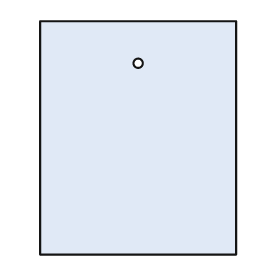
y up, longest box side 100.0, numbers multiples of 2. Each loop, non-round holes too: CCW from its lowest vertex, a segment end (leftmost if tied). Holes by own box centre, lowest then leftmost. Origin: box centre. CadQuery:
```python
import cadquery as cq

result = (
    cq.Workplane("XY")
    .moveTo(-42.0, -50.0)
    .lineTo(42.0, -50.0)
    .lineTo(42.0, 50.0)
    .lineTo(-42.0, 50.0)
    .close()
    .moveTo(0.0, 32.0)
    .circle(2.0)
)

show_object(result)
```